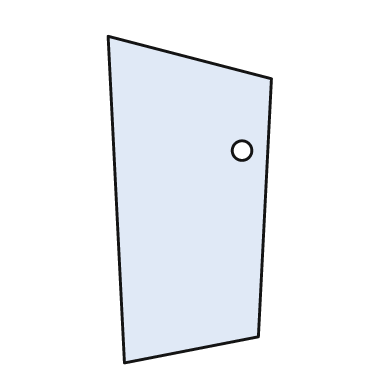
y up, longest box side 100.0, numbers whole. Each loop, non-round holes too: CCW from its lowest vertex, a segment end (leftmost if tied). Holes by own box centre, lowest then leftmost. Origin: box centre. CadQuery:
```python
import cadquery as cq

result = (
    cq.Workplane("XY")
    .moveTo(-20.0, -50.0)
    .lineTo(21.0, -42.0)
    .lineTo(25.0, 37.0)
    .lineTo(-25.0, 50.0)
    .close()
    .moveTo(16.0, 15.0)
    .circle(3.0)
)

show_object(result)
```